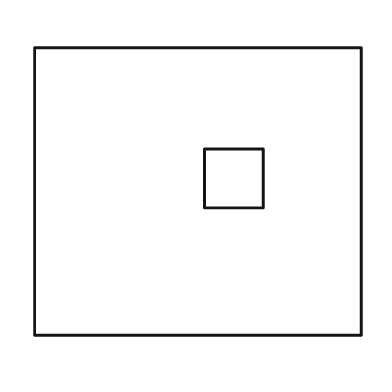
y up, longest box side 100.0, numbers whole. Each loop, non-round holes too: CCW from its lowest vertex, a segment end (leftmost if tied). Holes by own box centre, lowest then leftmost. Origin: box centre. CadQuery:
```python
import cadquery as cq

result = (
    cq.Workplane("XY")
    .moveTo(-50.0, -44.0)
    .lineTo(50.0, -44.0)
    .lineTo(50.0, 44.0)
    .lineTo(-50.0, 44.0)
    .close()
    .moveTo(2.0, -5.0)
    .lineTo(20.0, -5.0)
    .lineTo(20.0, 13.0)
    .lineTo(2.0, 13.0)
    .close()
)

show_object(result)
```